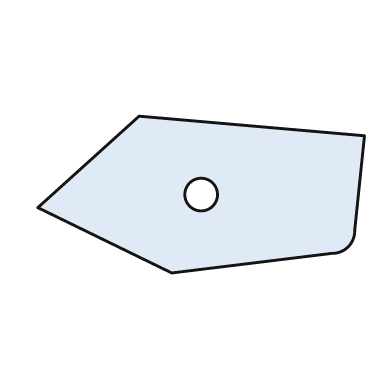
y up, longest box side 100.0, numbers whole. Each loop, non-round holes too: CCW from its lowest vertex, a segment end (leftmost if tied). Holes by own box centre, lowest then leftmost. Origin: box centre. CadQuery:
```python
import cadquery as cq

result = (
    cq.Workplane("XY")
    .moveTo(-9.0, -24.0)
    .lineTo(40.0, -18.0)
    .threePointArc((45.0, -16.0), (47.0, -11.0))
    .lineTo(50.0, 18.0)
    .lineTo(-19.0, 24.0)
    .lineTo(-50.0, -4.0)
    .close()
    .moveTo(0.0, 0.0)
    .circle(5.0)
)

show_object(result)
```